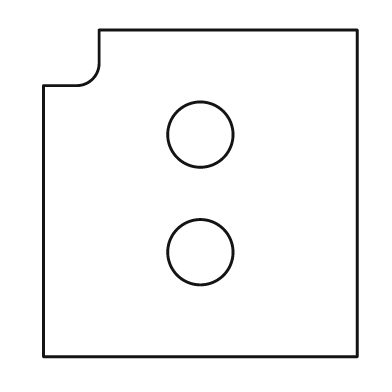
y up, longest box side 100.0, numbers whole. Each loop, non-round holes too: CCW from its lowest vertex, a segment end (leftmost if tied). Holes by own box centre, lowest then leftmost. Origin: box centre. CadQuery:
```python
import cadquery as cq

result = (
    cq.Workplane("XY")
    .moveTo(-48.0, -50.0)
    .lineTo(48.0, -50.0)
    .lineTo(48.0, 50.0)
    .lineTo(-31.0, 50.0)
    .lineTo(-31.0, 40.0)
    .threePointArc((-33.0, 35.0), (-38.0, 33.0))
    .lineTo(-48.0, 33.0)
    .close()
    .moveTo(0.0, -18.0)
    .circle(10.0)
    .moveTo(0.0, 18.0)
    .circle(10.0)
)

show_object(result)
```